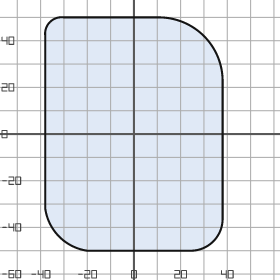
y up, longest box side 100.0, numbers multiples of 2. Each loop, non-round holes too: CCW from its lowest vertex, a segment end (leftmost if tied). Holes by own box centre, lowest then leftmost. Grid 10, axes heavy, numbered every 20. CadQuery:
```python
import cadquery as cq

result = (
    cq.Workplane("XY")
    .moveTo(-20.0, -50.0)
    .lineTo(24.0, -50.0)
    .threePointArc((34.0, -46.0), (38.0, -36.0))
    .lineTo(38.0, 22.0)
    .threePointArc((30.0, 42.0), (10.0, 50.0))
    .lineTo(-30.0, 50.0)
    .threePointArc((-36.0, 48.0), (-38.0, 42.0))
    .lineTo(-38.0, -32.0)
    .threePointArc((-32.0, -44.0), (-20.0, -50.0))
    .close()
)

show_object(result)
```